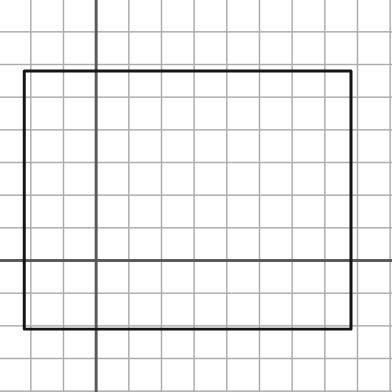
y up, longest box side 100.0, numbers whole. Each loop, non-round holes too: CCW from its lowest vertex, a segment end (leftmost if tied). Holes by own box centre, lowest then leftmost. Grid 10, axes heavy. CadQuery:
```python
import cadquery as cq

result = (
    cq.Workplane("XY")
    .moveTo(-22.0, -21.0)
    .lineTo(78.0, -21.0)
    .lineTo(78.0, 58.0)
    .lineTo(-22.0, 58.0)
    .close()
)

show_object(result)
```